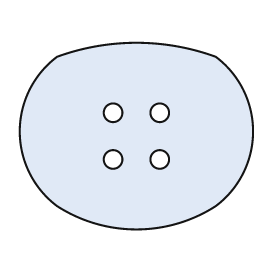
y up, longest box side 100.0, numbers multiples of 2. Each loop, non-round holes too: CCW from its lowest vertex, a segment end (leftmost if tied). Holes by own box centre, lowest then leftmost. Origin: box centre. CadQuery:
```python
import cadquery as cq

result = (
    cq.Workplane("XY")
    .moveTo(-34.0, -30.0)
    .threePointArc((0.0, -40.0), (34.0, -30.0))
    .threePointArc((50.0, 2.0), (34.0, 34.0))
    .threePointArc((0.0, 40.0), (-34.0, 34.0))
    .threePointArc((-50.0, 2.0), (-34.0, -30.0))
    .close()
    .moveTo(-10.0, -10.0)
    .circle(4.0)
    .moveTo(10.0, -10.0)
    .circle(4.0)
    .moveTo(-10.0, 10.0)
    .circle(4.0)
    .moveTo(10.0, 10.0)
    .circle(4.0)
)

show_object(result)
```